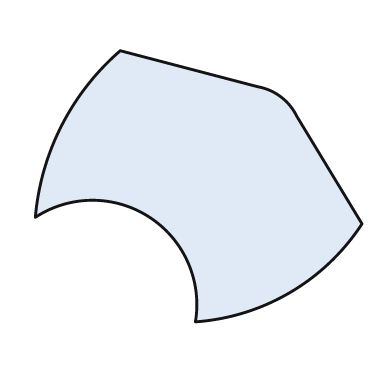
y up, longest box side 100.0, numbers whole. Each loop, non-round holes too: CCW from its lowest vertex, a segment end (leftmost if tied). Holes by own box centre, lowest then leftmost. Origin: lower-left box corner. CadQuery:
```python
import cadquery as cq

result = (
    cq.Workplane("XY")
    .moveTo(49.0, 0.0)
    .threePointArc((78.0, 9.0), (100.0, 30.0))
    .lineTo(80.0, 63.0)
    .threePointArc((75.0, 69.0), (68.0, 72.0))
    .lineTo(26.0, 83.0)
    .threePointArc((8.0, 60.0), (0.0, 32.0))
    .threePointArc((35.0, 32.0), (49.0, 0.0))
    .close()
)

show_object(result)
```